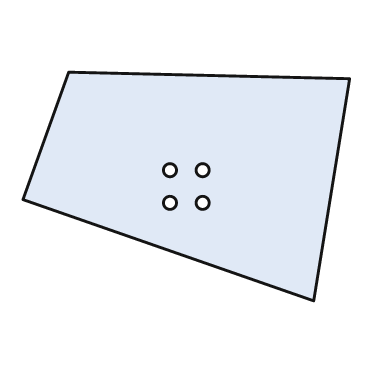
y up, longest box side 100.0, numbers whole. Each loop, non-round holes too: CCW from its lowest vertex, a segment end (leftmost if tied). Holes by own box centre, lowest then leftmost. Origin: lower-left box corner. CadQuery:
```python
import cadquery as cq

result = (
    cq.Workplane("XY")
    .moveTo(89.0, 0.0)
    .lineTo(100.0, 68.0)
    .lineTo(14.0, 70.0)
    .lineTo(0.0, 31.0)
    .close()
    .moveTo(45.0, 30.0)
    .circle(2.0)
    .moveTo(55.0, 30.0)
    .circle(2.0)
    .moveTo(45.0, 40.0)
    .circle(2.0)
    .moveTo(55.0, 40.0)
    .circle(2.0)
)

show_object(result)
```